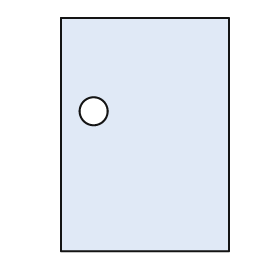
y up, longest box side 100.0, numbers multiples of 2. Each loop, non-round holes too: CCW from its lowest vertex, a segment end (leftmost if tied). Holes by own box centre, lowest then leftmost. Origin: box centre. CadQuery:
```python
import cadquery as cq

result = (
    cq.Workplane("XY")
    .moveTo(-36.0, -50.0)
    .lineTo(36.0, -50.0)
    .lineTo(36.0, 50.0)
    .lineTo(-36.0, 50.0)
    .close()
    .moveTo(-22.0, 10.0)
    .circle(6.0)
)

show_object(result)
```